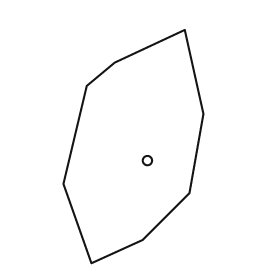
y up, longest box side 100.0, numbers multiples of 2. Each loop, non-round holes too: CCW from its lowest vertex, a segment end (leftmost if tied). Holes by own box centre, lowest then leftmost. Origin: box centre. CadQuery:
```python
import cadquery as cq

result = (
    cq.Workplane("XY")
    .moveTo(-18.0, -50.0)
    .lineTo(4.0, -40.0)
    .lineTo(24.0, -20.0)
    .lineTo(30.0, 14.0)
    .lineTo(22.0, 50.0)
    .lineTo(-8.0, 36.0)
    .lineTo(-20.0, 26.0)
    .lineTo(-30.0, -16.0)
    .close()
    .moveTo(6.0, -6.0)
    .circle(2.0)
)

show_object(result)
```